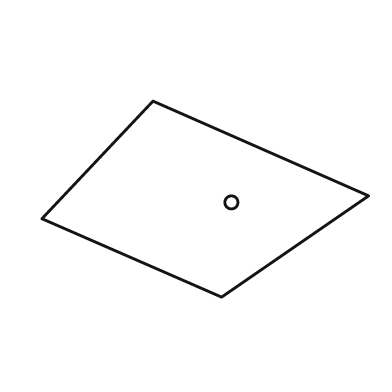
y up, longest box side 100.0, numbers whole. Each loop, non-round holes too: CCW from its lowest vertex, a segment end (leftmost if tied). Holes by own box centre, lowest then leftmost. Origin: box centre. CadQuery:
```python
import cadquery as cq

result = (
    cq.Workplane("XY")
    .moveTo(5.0, -30.0)
    .lineTo(50.0, 1.0)
    .lineTo(-16.0, 30.0)
    .lineTo(-50.0, -6.0)
    .close()
    .moveTo(8.0, -1.0)
    .circle(2.0)
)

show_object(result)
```